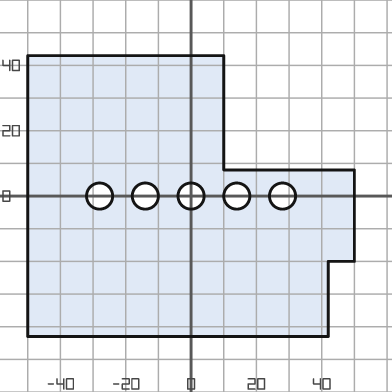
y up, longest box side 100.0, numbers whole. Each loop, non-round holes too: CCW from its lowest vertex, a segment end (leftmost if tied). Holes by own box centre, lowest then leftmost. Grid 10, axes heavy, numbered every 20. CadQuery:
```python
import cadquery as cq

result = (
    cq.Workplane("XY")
    .moveTo(-50.0, -43.0)
    .lineTo(42.0, -43.0)
    .lineTo(42.0, -20.0)
    .lineTo(50.0, -20.0)
    .lineTo(50.0, 8.0)
    .lineTo(10.0, 8.0)
    .lineTo(10.0, 43.0)
    .lineTo(-50.0, 43.0)
    .close()
    .moveTo(-28.0, 0.0)
    .circle(4.0)
    .moveTo(-14.0, 0.0)
    .circle(4.0)
    .moveTo(0.0, 0.0)
    .circle(4.0)
    .moveTo(14.0, 0.0)
    .circle(4.0)
    .moveTo(28.0, 0.0)
    .circle(4.0)
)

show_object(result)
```